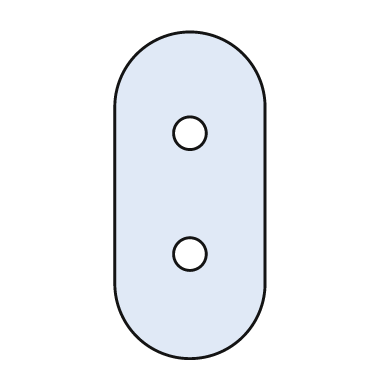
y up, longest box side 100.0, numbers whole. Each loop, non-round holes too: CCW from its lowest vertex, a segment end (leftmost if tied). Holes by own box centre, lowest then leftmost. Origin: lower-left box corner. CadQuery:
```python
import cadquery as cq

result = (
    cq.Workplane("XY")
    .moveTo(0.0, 23.0)
    .threePointArc((23.0, 0.0), (46.0, 23.0))
    .lineTo(46.0, 77.0)
    .threePointArc((23.0, 100.0), (0.0, 77.0))
    .close()
    .moveTo(23.0, 32.0)
    .circle(5.0)
    .moveTo(23.0, 69.0)
    .circle(5.0)
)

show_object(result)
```